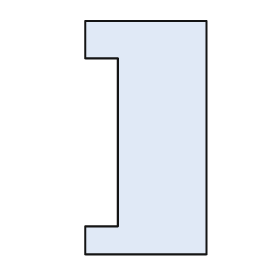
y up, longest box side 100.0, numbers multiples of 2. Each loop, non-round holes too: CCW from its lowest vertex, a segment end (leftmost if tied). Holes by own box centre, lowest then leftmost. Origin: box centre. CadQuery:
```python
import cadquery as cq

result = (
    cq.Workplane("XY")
    .moveTo(-26.0, -50.0)
    .lineTo(26.0, -50.0)
    .lineTo(26.0, 50.0)
    .lineTo(-26.0, 50.0)
    .lineTo(-26.0, 34.0)
    .lineTo(-12.0, 34.0)
    .lineTo(-12.0, -38.0)
    .lineTo(-26.0, -38.0)
    .close()
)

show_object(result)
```